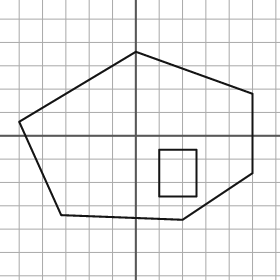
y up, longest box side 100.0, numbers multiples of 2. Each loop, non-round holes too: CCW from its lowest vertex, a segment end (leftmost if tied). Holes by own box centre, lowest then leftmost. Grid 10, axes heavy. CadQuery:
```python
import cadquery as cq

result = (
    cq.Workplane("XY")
    .moveTo(20.0, -36.0)
    .lineTo(50.0, -16.0)
    .lineTo(50.0, 18.0)
    .lineTo(0.0, 36.0)
    .lineTo(-50.0, 6.0)
    .lineTo(-32.0, -34.0)
    .close()
    .moveTo(10.0, -26.0)
    .lineTo(26.0, -26.0)
    .lineTo(26.0, -6.0)
    .lineTo(10.0, -6.0)
    .close()
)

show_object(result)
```